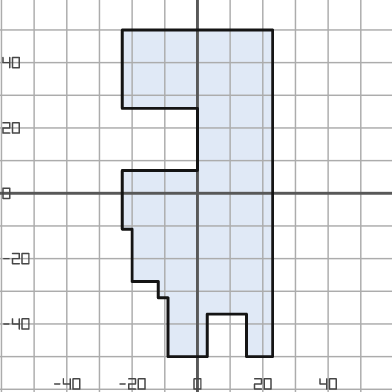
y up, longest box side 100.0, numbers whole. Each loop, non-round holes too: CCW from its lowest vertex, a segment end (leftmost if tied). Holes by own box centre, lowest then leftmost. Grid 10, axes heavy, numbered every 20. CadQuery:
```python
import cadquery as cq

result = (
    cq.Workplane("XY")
    .moveTo(-9.0, -50.0)
    .lineTo(3.0, -50.0)
    .lineTo(3.0, -37.0)
    .lineTo(15.0, -37.0)
    .lineTo(15.0, -50.0)
    .lineTo(23.0, -50.0)
    .lineTo(23.0, 50.0)
    .lineTo(-23.0, 50.0)
    .lineTo(-23.0, 26.0)
    .lineTo(0.0, 26.0)
    .lineTo(0.0, 7.0)
    .lineTo(-23.0, 7.0)
    .lineTo(-23.0, -11.0)
    .lineTo(-20.0, -11.0)
    .lineTo(-20.0, -27.0)
    .lineTo(-12.0, -27.0)
    .lineTo(-12.0, -32.0)
    .lineTo(-9.0, -32.0)
    .close()
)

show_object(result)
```